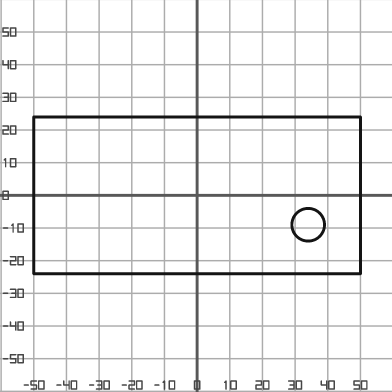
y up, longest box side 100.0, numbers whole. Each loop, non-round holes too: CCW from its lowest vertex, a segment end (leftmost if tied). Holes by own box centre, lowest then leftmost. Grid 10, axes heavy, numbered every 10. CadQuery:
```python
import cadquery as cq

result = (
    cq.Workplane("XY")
    .moveTo(-50.0, -24.0)
    .lineTo(50.0, -24.0)
    .lineTo(50.0, 24.0)
    .lineTo(-50.0, 24.0)
    .close()
    .moveTo(34.0, -9.0)
    .circle(5.0)
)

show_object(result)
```